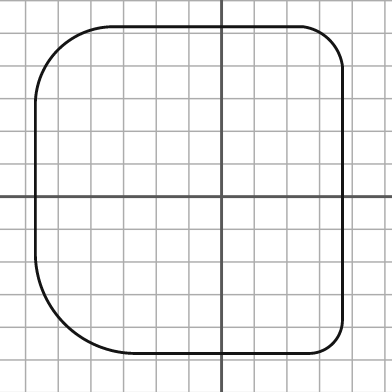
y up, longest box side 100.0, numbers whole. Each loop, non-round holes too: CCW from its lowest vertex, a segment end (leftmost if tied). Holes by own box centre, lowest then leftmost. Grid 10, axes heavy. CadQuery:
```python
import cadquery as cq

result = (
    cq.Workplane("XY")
    .moveTo(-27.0, -48.0)
    .lineTo(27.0, -48.0)
    .threePointArc((34.0, -45.0), (37.0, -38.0))
    .lineTo(37.0, 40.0)
    .threePointArc((33.0, 48.0), (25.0, 52.0))
    .lineTo(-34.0, 52.0)
    .threePointArc((-50.0, 45.0), (-57.0, 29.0))
    .lineTo(-57.0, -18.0)
    .threePointArc((-48.0, -39.0), (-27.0, -48.0))
    .close()
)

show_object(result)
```